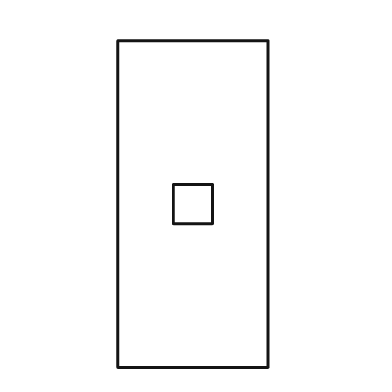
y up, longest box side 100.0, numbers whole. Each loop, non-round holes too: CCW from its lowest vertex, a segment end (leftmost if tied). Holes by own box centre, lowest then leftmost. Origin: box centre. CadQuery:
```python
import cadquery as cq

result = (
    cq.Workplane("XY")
    .moveTo(-23.0, -50.0)
    .lineTo(23.0, -50.0)
    .lineTo(23.0, 50.0)
    .lineTo(-23.0, 50.0)
    .close()
    .moveTo(-6.0, -6.0)
    .lineTo(6.0, -6.0)
    .lineTo(6.0, 6.0)
    .lineTo(-6.0, 6.0)
    .close()
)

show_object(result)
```